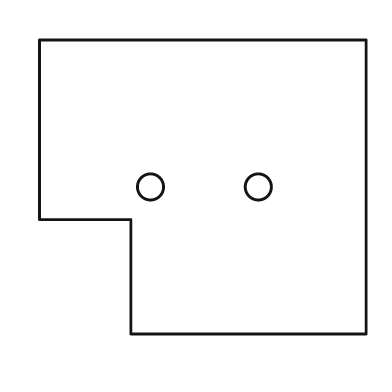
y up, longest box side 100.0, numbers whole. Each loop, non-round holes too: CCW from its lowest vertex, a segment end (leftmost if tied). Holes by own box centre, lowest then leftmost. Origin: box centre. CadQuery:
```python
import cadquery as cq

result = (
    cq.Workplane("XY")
    .moveTo(-22.0, -45.0)
    .lineTo(50.0, -45.0)
    .lineTo(50.0, 45.0)
    .lineTo(-50.0, 45.0)
    .lineTo(-50.0, -10.0)
    .lineTo(-22.0, -10.0)
    .close()
    .moveTo(-16.0, 0.0)
    .circle(4.0)
    .moveTo(17.0, 0.0)
    .circle(4.0)
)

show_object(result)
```